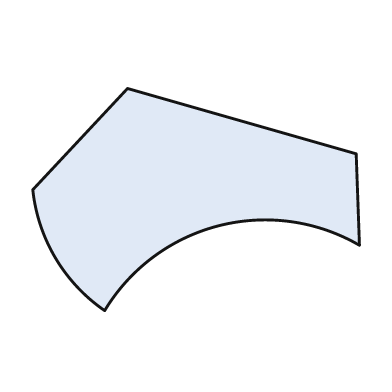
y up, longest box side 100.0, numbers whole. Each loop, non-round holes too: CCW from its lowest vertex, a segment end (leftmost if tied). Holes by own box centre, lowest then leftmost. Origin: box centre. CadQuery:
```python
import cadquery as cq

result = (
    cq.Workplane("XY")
    .moveTo(-28.0, -34.0)
    .threePointArc((7.0, -8.0), (50.0, -14.0))
    .lineTo(49.0, 14.0)
    .lineTo(-21.0, 34.0)
    .lineTo(-50.0, 3.0)
    .threePointArc((-43.0, -18.0), (-28.0, -34.0))
    .close()
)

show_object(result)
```